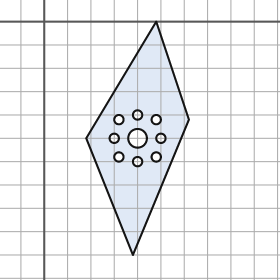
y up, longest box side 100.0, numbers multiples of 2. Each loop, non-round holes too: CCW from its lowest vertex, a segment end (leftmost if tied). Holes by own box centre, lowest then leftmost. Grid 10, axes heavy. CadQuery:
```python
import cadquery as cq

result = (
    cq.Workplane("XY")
    .moveTo(38.0, -100.0)
    .lineTo(62.0, -42.0)
    .lineTo(48.0, 0.0)
    .lineTo(18.0, -50.0)
    .close()
    .moveTo(40.0, -60.0)
    .circle(2.0)
    .moveTo(32.0, -58.0)
    .circle(2.0)
    .moveTo(48.0, -58.0)
    .circle(2.0)
    .moveTo(30.0, -50.0)
    .circle(2.0)
    .moveTo(40.0, -50.0)
    .circle(4.0)
    .moveTo(50.0, -50.0)
    .circle(2.0)
    .moveTo(32.0, -42.0)
    .circle(2.0)
    .moveTo(48.0, -42.0)
    .circle(2.0)
    .moveTo(40.0, -40.0)
    .circle(2.0)
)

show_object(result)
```